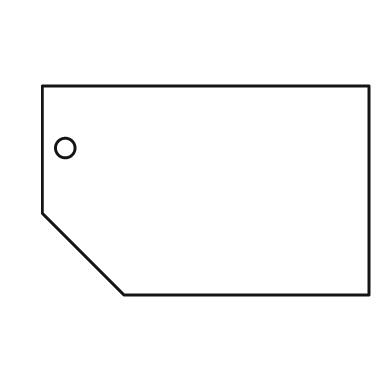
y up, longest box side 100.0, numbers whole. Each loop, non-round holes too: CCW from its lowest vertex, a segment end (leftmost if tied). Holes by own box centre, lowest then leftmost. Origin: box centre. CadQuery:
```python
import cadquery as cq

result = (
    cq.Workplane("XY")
    .moveTo(-25.0, -32.0)
    .lineTo(50.0, -32.0)
    .lineTo(50.0, 32.0)
    .lineTo(-50.0, 32.0)
    .lineTo(-50.0, -7.0)
    .close()
    .moveTo(-43.0, 13.0)
    .circle(3.0)
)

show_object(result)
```